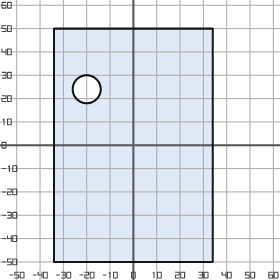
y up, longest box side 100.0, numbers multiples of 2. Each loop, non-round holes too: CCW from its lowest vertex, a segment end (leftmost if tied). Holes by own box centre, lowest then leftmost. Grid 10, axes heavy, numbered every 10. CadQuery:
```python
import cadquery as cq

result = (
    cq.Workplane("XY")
    .moveTo(-34.0, -50.0)
    .lineTo(34.0, -50.0)
    .lineTo(34.0, 50.0)
    .lineTo(-34.0, 50.0)
    .close()
    .moveTo(-20.0, 24.0)
    .circle(6.0)
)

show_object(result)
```